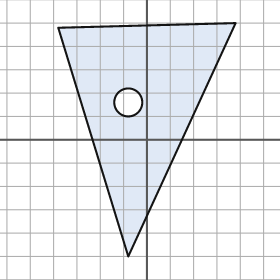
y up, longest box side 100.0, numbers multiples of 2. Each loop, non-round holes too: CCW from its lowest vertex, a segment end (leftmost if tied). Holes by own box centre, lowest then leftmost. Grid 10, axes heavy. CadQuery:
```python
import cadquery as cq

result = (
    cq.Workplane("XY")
    .moveTo(-8.0, -50.0)
    .lineTo(38.0, 50.0)
    .lineTo(-38.0, 48.0)
    .close()
    .moveTo(-8.0, 16.0)
    .circle(6.0)
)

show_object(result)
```